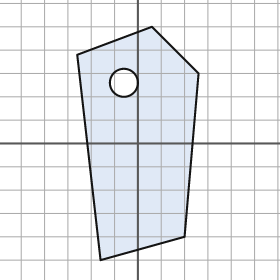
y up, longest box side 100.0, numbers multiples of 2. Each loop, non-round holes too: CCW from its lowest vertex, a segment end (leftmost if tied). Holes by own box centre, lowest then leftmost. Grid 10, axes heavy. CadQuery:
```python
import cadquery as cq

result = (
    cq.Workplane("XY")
    .moveTo(-16.0, -50.0)
    .lineTo(20.0, -40.0)
    .lineTo(26.0, 30.0)
    .lineTo(6.0, 50.0)
    .lineTo(-26.0, 38.0)
    .close()
    .moveTo(-6.0, 26.0)
    .circle(6.0)
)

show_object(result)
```